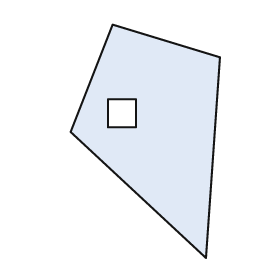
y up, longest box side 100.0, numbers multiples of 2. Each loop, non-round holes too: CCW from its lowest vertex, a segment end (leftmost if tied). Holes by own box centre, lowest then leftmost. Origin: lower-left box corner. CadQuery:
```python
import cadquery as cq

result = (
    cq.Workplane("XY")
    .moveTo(58.0, 0.0)
    .lineTo(64.0, 86.0)
    .lineTo(18.0, 100.0)
    .lineTo(0.0, 54.0)
    .close()
    .moveTo(16.0, 56.0)
    .lineTo(28.0, 56.0)
    .lineTo(28.0, 68.0)
    .lineTo(16.0, 68.0)
    .close()
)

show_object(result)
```